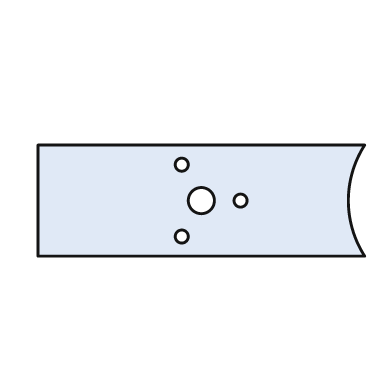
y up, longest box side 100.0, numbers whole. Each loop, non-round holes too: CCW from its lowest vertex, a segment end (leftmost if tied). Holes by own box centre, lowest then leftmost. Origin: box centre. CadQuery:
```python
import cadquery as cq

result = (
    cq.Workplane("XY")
    .moveTo(-50.0, -17.0)
    .lineTo(50.0, -17.0)
    .threePointArc((45.0, 0.0), (50.0, 17.0))
    .lineTo(-50.0, 17.0)
    .close()
    .moveTo(-6.0, -11.0)
    .circle(2.0)
    .moveTo(0.0, 0.0)
    .circle(4.0)
    .moveTo(12.0, 0.0)
    .circle(2.0)
    .moveTo(-6.0, 11.0)
    .circle(2.0)
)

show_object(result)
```